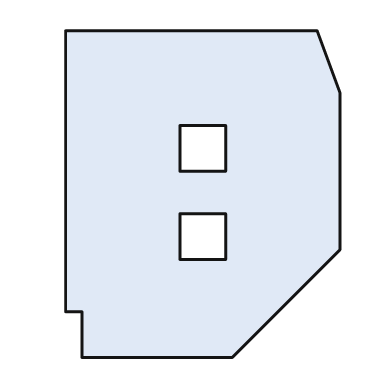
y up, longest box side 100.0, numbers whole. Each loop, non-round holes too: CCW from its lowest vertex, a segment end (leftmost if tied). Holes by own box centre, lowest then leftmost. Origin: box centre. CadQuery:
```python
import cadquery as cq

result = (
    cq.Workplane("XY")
    .moveTo(-37.0, -50.0)
    .lineTo(9.0, -50.0)
    .lineTo(42.0, -17.0)
    .lineTo(42.0, 31.0)
    .lineTo(35.0, 50.0)
    .lineTo(-42.0, 50.0)
    .lineTo(-42.0, -36.0)
    .lineTo(-37.0, -36.0)
    .close()
    .moveTo(-7.0, -20.0)
    .lineTo(7.0, -20.0)
    .lineTo(7.0, -6.0)
    .lineTo(-7.0, -6.0)
    .close()
    .moveTo(-7.0, 7.0)
    .lineTo(7.0, 7.0)
    .lineTo(7.0, 21.0)
    .lineTo(-7.0, 21.0)
    .close()
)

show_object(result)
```